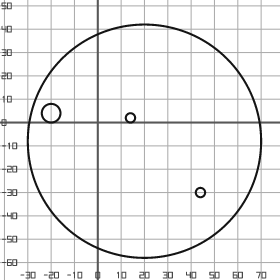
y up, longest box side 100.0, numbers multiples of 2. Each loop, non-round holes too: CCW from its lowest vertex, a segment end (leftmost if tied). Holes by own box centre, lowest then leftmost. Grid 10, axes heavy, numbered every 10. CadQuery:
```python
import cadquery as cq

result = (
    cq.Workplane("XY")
    .moveTo(20.0, -8.0)
    .circle(50.0)
    .moveTo(44.0, -30.0)
    .circle(2.0)
    .moveTo(14.0, 2.0)
    .circle(2.0)
    .moveTo(-20.0, 4.0)
    .circle(4.0)
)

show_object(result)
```